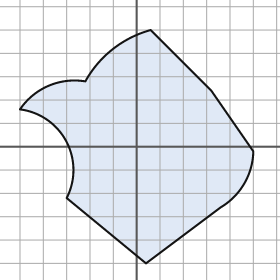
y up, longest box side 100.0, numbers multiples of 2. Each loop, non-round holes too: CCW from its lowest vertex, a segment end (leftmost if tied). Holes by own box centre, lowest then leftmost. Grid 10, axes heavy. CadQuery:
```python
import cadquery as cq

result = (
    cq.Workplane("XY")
    .moveTo(4.0, -50.0)
    .lineTo(36.0, -26.0)
    .threePointArc((46.0, -16.0), (50.0, -2.0))
    .lineTo(32.0, 24.0)
    .lineTo(6.0, 50.0)
    .threePointArc((-10.0, 42.0), (-22.0, 28.0))
    .threePointArc((-38.0, 26.0), (-50.0, 16.0))
    .threePointArc((-30.0, 2.0), (-30.0, -22.0))
    .close()
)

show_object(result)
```